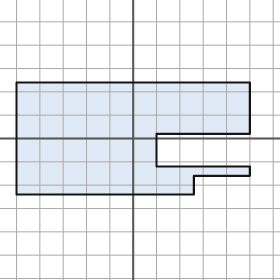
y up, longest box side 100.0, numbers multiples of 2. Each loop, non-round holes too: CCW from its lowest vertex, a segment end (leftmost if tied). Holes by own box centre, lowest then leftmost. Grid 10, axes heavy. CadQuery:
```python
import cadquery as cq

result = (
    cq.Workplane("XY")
    .moveTo(-50.0, -24.0)
    .lineTo(26.0, -24.0)
    .lineTo(26.0, -16.0)
    .lineTo(50.0, -16.0)
    .lineTo(50.0, -12.0)
    .lineTo(10.0, -12.0)
    .lineTo(10.0, 2.0)
    .lineTo(50.0, 2.0)
    .lineTo(50.0, 24.0)
    .lineTo(-50.0, 24.0)
    .close()
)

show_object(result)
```